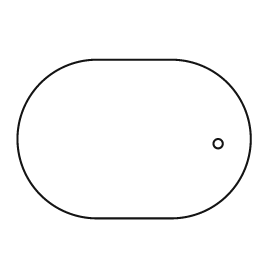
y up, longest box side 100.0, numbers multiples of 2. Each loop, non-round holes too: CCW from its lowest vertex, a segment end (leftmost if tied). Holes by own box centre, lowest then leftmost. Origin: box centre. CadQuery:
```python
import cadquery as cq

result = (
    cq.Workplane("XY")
    .moveTo(-16.0, -34.0)
    .lineTo(16.0, -34.0)
    .threePointArc((50.0, 0.0), (16.0, 34.0))
    .lineTo(-16.0, 34.0)
    .threePointArc((-50.0, 0.0), (-16.0, -34.0))
    .close()
    .moveTo(36.0, -2.0)
    .circle(2.0)
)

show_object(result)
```